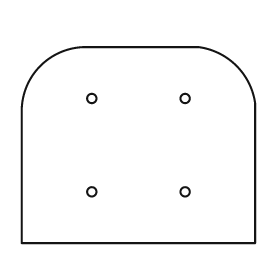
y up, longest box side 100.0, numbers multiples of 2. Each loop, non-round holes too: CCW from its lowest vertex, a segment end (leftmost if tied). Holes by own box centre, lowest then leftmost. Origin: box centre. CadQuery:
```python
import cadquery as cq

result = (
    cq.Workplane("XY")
    .moveTo(-50.0, -42.0)
    .lineTo(50.0, -42.0)
    .lineTo(50.0, 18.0)
    .threePointArc((42.0, 34.0), (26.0, 42.0))
    .lineTo(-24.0, 42.0)
    .threePointArc((-42.0, 34.0), (-50.0, 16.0))
    .close()
    .moveTo(-20.0, -20.0)
    .circle(2.0)
    .moveTo(20.0, -20.0)
    .circle(2.0)
    .moveTo(-20.0, 20.0)
    .circle(2.0)
    .moveTo(20.0, 20.0)
    .circle(2.0)
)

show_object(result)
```